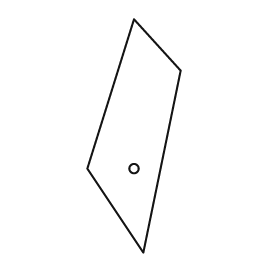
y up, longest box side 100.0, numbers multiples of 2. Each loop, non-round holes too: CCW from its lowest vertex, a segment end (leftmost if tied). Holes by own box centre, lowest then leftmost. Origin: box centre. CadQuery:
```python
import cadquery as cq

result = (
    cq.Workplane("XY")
    .moveTo(4.0, -50.0)
    .lineTo(20.0, 28.0)
    .lineTo(0.0, 50.0)
    .lineTo(-20.0, -14.0)
    .close()
    .moveTo(0.0, -14.0)
    .circle(2.0)
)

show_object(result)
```